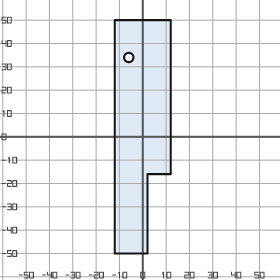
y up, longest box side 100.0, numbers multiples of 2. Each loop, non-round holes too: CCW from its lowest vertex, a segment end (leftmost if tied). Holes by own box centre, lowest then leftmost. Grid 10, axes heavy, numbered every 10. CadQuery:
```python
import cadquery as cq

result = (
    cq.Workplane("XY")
    .moveTo(-12.0, -50.0)
    .lineTo(2.0, -50.0)
    .lineTo(2.0, -16.0)
    .lineTo(12.0, -16.0)
    .lineTo(12.0, 50.0)
    .lineTo(-12.0, 50.0)
    .close()
    .moveTo(-6.0, 34.0)
    .circle(2.0)
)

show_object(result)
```